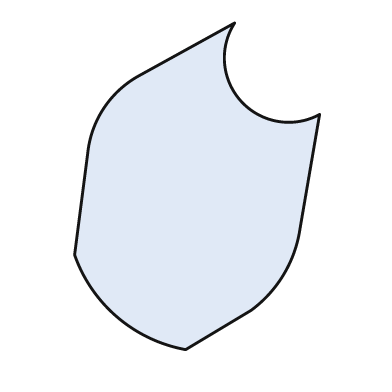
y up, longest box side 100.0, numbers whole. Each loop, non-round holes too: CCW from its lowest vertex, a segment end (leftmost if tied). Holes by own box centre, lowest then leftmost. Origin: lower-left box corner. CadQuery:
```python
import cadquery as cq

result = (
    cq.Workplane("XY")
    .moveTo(34.0, 0.0)
    .lineTo(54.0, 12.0)
    .threePointArc((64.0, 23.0), (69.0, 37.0))
    .lineTo(75.0, 72.0)
    .threePointArc((51.0, 76.0), (49.0, 100.0))
    .lineTo(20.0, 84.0)
    .threePointArc((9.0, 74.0), (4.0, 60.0))
    .lineTo(0.0, 29.0)
    .threePointArc((13.0, 10.0), (34.0, 0.0))
    .close()
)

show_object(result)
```